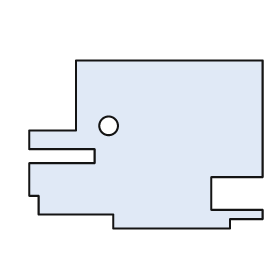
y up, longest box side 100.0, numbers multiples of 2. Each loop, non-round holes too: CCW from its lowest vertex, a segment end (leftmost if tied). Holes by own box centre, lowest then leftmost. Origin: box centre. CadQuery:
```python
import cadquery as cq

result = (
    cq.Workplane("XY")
    .moveTo(-14.0, -36.0)
    .lineTo(36.0, -36.0)
    .lineTo(36.0, -32.0)
    .lineTo(50.0, -32.0)
    .lineTo(50.0, -28.0)
    .lineTo(28.0, -28.0)
    .lineTo(28.0, -14.0)
    .lineTo(50.0, -14.0)
    .lineTo(50.0, 36.0)
    .lineTo(-30.0, 36.0)
    .lineTo(-30.0, 6.0)
    .lineTo(-50.0, 6.0)
    .lineTo(-50.0, -2.0)
    .lineTo(-22.0, -2.0)
    .lineTo(-22.0, -8.0)
    .lineTo(-50.0, -8.0)
    .lineTo(-50.0, -22.0)
    .lineTo(-46.0, -22.0)
    .lineTo(-46.0, -30.0)
    .lineTo(-14.0, -30.0)
    .close()
    .moveTo(-16.0, 8.0)
    .circle(4.0)
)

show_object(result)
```